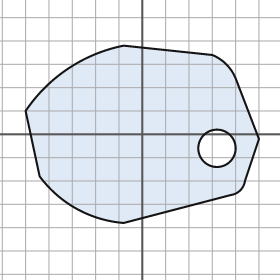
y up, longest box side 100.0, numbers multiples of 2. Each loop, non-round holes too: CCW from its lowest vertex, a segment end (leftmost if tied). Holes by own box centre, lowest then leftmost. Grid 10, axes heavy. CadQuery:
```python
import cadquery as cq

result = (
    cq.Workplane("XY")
    .moveTo(-8.0, -38.0)
    .lineTo(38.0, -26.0)
    .threePointArc((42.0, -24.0), (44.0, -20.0))
    .lineTo(50.0, -2.0)
    .lineTo(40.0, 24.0)
    .threePointArc((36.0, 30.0), (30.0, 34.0))
    .lineTo(-8.0, 38.0)
    .threePointArc((-32.0, 28.0), (-50.0, 10.0))
    .lineTo(-44.0, -18.0)
    .threePointArc((-28.0, -32.0), (-8.0, -38.0))
    .close()
    .moveTo(32.0, -6.0)
    .circle(8.0)
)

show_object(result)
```